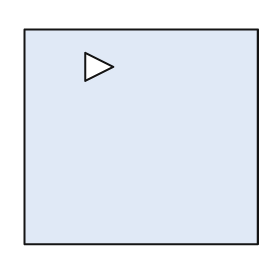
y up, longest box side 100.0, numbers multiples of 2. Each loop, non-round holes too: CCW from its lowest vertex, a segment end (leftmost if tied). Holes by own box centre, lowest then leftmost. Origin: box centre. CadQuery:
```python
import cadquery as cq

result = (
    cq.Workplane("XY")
    .moveTo(-50.0, -46.0)
    .lineTo(50.0, -46.0)
    .lineTo(50.0, 46.0)
    .lineTo(-50.0, 46.0)
    .close()
    .moveTo(-24.0, 24.0)
    .lineTo(-12.0, 30.0)
    .lineTo(-24.0, 36.0)
    .close()
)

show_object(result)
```